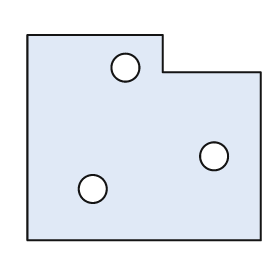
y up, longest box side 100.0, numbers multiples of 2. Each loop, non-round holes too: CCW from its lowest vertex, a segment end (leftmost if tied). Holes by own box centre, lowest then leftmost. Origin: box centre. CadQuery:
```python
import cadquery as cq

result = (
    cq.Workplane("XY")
    .moveTo(-50.0, -44.0)
    .lineTo(50.0, -44.0)
    .lineTo(50.0, 28.0)
    .lineTo(8.0, 28.0)
    .lineTo(8.0, 44.0)
    .lineTo(-50.0, 44.0)
    .close()
    .moveTo(-22.0, -22.0)
    .circle(6.0)
    .moveTo(30.0, -8.0)
    .circle(6.0)
    .moveTo(-8.0, 30.0)
    .circle(6.0)
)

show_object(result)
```